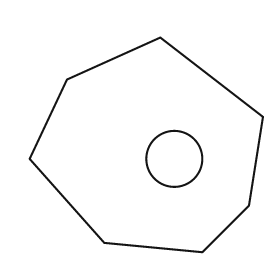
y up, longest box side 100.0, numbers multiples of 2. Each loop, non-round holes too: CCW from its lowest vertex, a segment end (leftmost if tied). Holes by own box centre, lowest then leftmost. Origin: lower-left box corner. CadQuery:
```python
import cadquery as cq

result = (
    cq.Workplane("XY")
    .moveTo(74.0, 0.0)
    .lineTo(94.0, 20.0)
    .lineTo(100.0, 58.0)
    .lineTo(56.0, 92.0)
    .lineTo(16.0, 74.0)
    .lineTo(0.0, 40.0)
    .lineTo(32.0, 4.0)
    .close()
    .moveTo(62.0, 40.0)
    .circle(12.0)
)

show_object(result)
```